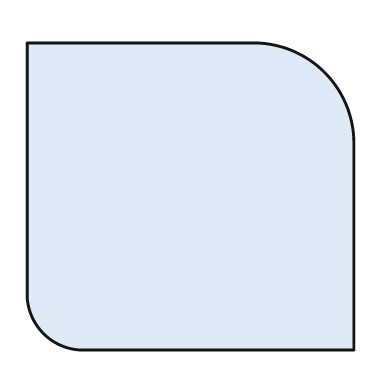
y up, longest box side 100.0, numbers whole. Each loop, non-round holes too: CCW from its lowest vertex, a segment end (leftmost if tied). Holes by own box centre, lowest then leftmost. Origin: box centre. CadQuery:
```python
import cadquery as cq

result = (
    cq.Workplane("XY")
    .moveTo(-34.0, -47.0)
    .lineTo(50.0, -47.0)
    .lineTo(50.0, 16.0)
    .threePointArc((41.0, 38.0), (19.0, 47.0))
    .lineTo(-50.0, 47.0)
    .lineTo(-50.0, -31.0)
    .threePointArc((-45.0, -42.0), (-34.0, -47.0))
    .close()
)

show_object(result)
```